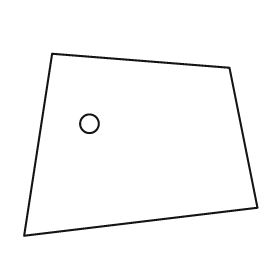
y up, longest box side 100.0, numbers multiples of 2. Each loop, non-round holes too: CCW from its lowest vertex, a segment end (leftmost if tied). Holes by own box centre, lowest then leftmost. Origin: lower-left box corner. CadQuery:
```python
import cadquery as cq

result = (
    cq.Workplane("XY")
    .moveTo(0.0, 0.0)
    .lineTo(100.0, 12.0)
    .lineTo(88.0, 72.0)
    .lineTo(12.0, 78.0)
    .close()
    .moveTo(28.0, 48.0)
    .circle(4.0)
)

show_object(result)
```